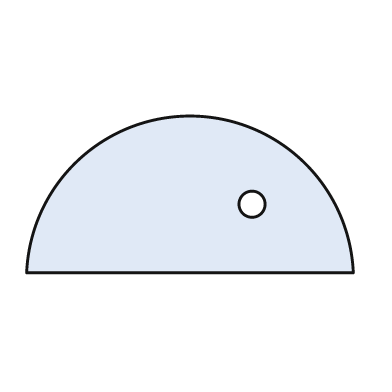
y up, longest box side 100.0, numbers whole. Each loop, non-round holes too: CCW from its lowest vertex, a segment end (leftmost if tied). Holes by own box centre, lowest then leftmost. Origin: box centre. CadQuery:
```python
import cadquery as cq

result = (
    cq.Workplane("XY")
    .moveTo(-50.0, -24.0)
    .lineTo(50.0, -24.0)
    .threePointArc((0.0, 24.0), (-50.0, -24.0))
    .close()
    .moveTo(19.0, -3.0)
    .circle(4.0)
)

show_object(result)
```